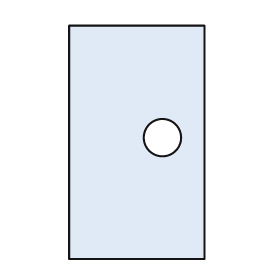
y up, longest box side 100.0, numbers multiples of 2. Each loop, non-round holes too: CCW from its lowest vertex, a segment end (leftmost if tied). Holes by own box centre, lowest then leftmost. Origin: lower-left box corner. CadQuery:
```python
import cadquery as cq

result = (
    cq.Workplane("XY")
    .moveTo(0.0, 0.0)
    .lineTo(58.0, 0.0)
    .lineTo(58.0, 100.0)
    .lineTo(0.0, 100.0)
    .close()
    .moveTo(40.0, 52.0)
    .circle(8.0)
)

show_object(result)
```